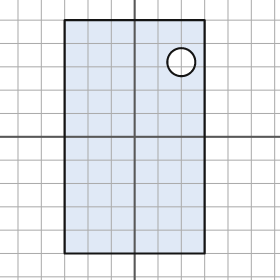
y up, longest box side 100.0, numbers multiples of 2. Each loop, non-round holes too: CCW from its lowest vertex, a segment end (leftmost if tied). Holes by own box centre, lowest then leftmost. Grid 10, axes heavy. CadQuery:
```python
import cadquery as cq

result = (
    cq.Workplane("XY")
    .moveTo(-30.0, -50.0)
    .lineTo(30.0, -50.0)
    .lineTo(30.0, 50.0)
    .lineTo(-30.0, 50.0)
    .close()
    .moveTo(20.0, 32.0)
    .circle(6.0)
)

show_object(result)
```